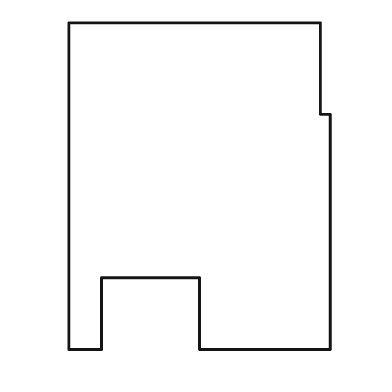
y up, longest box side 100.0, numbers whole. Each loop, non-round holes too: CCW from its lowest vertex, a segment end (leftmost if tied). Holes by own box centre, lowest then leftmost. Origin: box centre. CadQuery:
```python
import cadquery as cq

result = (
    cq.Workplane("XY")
    .moveTo(-40.0, -50.0)
    .lineTo(-30.0, -50.0)
    .lineTo(-30.0, -28.0)
    .lineTo(0.0, -28.0)
    .lineTo(0.0, -50.0)
    .lineTo(40.0, -50.0)
    .lineTo(40.0, 22.0)
    .lineTo(37.0, 22.0)
    .lineTo(37.0, 50.0)
    .lineTo(-40.0, 50.0)
    .close()
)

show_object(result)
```